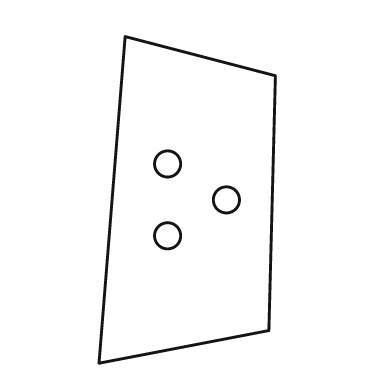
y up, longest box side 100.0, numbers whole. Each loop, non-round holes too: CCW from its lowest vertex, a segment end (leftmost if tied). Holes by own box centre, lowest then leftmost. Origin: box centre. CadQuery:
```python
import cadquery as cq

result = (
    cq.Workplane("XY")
    .moveTo(-27.0, -50.0)
    .lineTo(25.0, -40.0)
    .lineTo(27.0, 38.0)
    .lineTo(-19.0, 50.0)
    .close()
    .moveTo(-6.0, -11.0)
    .circle(4.0)
    .moveTo(12.0, 0.0)
    .circle(4.0)
    .moveTo(-6.0, 11.0)
    .circle(4.0)
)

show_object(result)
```